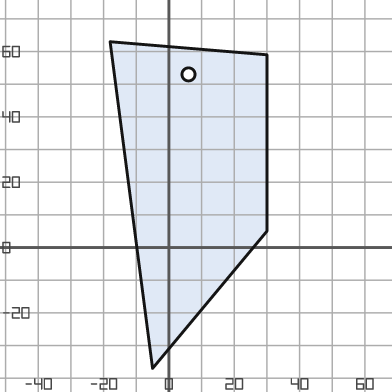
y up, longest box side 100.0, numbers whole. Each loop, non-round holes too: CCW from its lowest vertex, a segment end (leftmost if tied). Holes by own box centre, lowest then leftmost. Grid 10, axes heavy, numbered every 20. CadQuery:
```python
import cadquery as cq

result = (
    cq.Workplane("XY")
    .moveTo(-5.0, -37.0)
    .lineTo(30.0, 5.0)
    .lineTo(30.0, 59.0)
    .lineTo(-18.0, 63.0)
    .close()
    .moveTo(6.0, 53.0)
    .circle(2.0)
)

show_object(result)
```